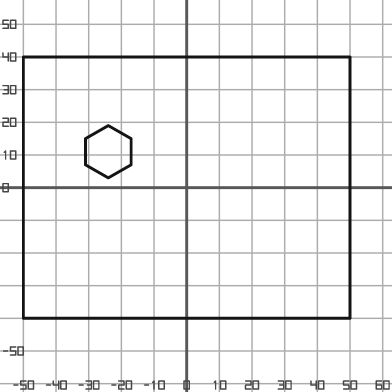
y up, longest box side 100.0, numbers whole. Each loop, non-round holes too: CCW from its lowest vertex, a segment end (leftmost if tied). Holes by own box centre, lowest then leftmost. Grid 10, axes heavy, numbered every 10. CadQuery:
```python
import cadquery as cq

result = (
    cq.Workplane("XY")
    .moveTo(-50.0, -40.0)
    .lineTo(50.0, -40.0)
    .lineTo(50.0, 40.0)
    .lineTo(-50.0, 40.0)
    .close()
    .moveTo(-24.0, 3.0)
    .lineTo(-17.0, 7.0)
    .lineTo(-17.0, 15.0)
    .lineTo(-24.0, 19.0)
    .lineTo(-31.0, 15.0)
    .lineTo(-31.0, 7.0)
    .close()
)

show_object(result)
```